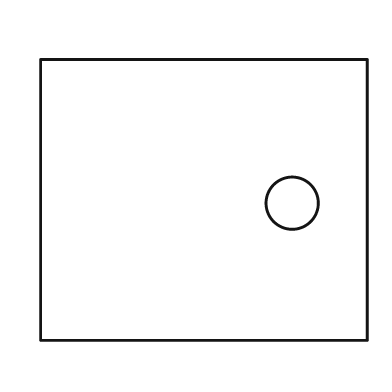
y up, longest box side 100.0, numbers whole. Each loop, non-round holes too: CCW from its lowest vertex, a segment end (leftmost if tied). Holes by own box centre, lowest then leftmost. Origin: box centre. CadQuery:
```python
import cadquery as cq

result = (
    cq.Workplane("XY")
    .moveTo(-50.0, -43.0)
    .lineTo(50.0, -43.0)
    .lineTo(50.0, 43.0)
    .lineTo(-50.0, 43.0)
    .close()
    .moveTo(27.0, -1.0)
    .circle(8.0)
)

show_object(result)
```